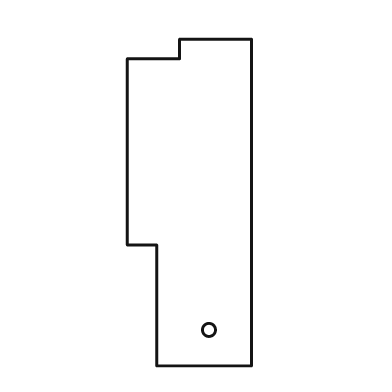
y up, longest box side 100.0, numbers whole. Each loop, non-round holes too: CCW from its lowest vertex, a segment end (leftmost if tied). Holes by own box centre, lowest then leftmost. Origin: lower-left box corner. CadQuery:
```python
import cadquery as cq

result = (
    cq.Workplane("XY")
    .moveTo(9.0, 0.0)
    .lineTo(38.0, 0.0)
    .lineTo(38.0, 100.0)
    .lineTo(16.0, 100.0)
    .lineTo(16.0, 94.0)
    .lineTo(0.0, 94.0)
    .lineTo(0.0, 37.0)
    .lineTo(9.0, 37.0)
    .close()
    .moveTo(25.0, 11.0)
    .circle(2.0)
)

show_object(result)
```